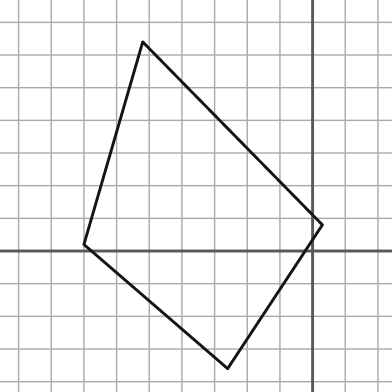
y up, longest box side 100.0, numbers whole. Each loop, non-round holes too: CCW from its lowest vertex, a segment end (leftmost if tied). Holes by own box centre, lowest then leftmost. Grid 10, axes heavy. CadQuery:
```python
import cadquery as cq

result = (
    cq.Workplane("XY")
    .moveTo(-26.0, -36.0)
    .lineTo(3.0, 8.0)
    .lineTo(-52.0, 64.0)
    .lineTo(-70.0, 2.0)
    .close()
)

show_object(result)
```